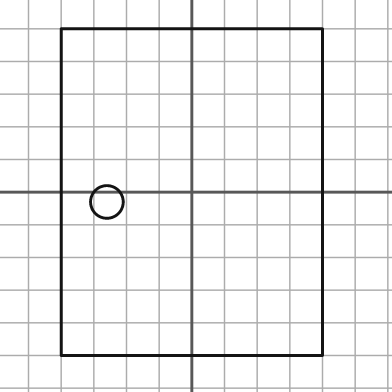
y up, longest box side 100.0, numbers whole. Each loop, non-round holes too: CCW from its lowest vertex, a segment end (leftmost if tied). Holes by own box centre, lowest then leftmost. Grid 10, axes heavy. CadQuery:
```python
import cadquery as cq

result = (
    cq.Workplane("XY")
    .moveTo(-40.0, -50.0)
    .lineTo(40.0, -50.0)
    .lineTo(40.0, 50.0)
    .lineTo(-40.0, 50.0)
    .close()
    .moveTo(-26.0, -3.0)
    .circle(5.0)
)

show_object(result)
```